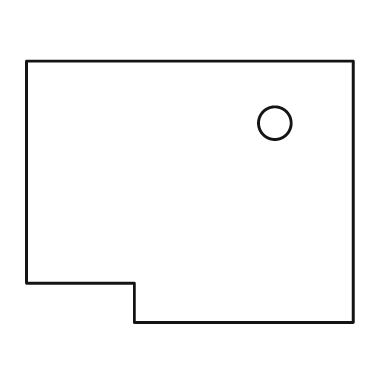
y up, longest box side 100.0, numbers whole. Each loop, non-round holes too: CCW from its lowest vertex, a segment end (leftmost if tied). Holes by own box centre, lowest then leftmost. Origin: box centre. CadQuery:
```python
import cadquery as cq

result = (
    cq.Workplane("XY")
    .moveTo(-17.0, -40.0)
    .lineTo(50.0, -40.0)
    .lineTo(50.0, 40.0)
    .lineTo(-50.0, 40.0)
    .lineTo(-50.0, -28.0)
    .lineTo(-17.0, -28.0)
    .close()
    .moveTo(26.0, 21.0)
    .circle(5.0)
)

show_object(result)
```